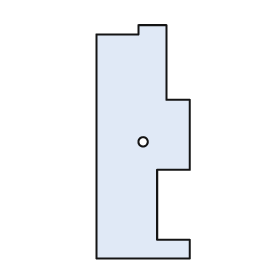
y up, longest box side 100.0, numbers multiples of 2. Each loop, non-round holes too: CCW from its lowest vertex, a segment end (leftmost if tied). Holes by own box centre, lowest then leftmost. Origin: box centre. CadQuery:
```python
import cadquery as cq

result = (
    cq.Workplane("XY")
    .moveTo(-20.0, -50.0)
    .lineTo(20.0, -50.0)
    .lineTo(20.0, -42.0)
    .lineTo(6.0, -42.0)
    .lineTo(6.0, -12.0)
    .lineTo(20.0, -12.0)
    .lineTo(20.0, 18.0)
    .lineTo(10.0, 18.0)
    .lineTo(10.0, 50.0)
    .lineTo(-2.0, 50.0)
    .lineTo(-2.0, 46.0)
    .lineTo(-20.0, 46.0)
    .close()
    .moveTo(0.0, 0.0)
    .circle(2.0)
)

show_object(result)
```